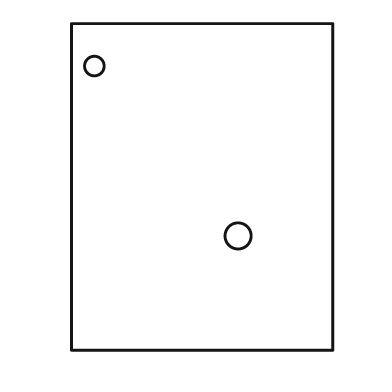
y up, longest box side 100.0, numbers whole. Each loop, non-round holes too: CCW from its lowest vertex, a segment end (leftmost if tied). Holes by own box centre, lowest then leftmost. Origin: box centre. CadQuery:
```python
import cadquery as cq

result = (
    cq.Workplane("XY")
    .moveTo(-40.0, -50.0)
    .lineTo(40.0, -50.0)
    .lineTo(40.0, 50.0)
    .lineTo(-40.0, 50.0)
    .close()
    .moveTo(11.0, -15.0)
    .circle(4.0)
    .moveTo(-33.0, 37.0)
    .circle(3.0)
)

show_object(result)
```